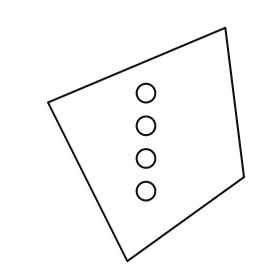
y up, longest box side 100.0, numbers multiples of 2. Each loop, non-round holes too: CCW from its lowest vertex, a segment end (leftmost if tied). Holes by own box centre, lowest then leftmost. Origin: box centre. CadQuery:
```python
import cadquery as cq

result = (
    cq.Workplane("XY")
    .moveTo(-8.0, -50.0)
    .lineTo(42.0, -14.0)
    .lineTo(34.0, 50.0)
    .lineTo(-42.0, 18.0)
    .close()
    .moveTo(0.0, -20.0)
    .circle(4.0)
    .moveTo(0.0, -6.0)
    .circle(4.0)
    .moveTo(0.0, 8.0)
    .circle(4.0)
    .moveTo(0.0, 22.0)
    .circle(4.0)
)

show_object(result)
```